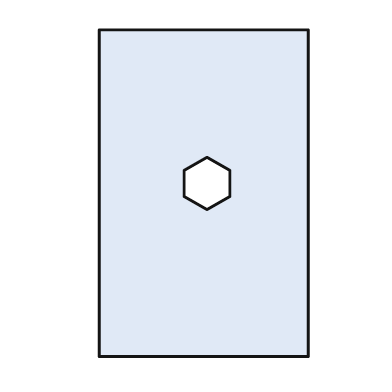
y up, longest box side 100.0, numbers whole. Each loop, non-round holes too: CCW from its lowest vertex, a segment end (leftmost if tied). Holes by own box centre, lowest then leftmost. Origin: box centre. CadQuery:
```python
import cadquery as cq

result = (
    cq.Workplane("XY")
    .moveTo(-32.0, -50.0)
    .lineTo(32.0, -50.0)
    .lineTo(32.0, 50.0)
    .lineTo(-32.0, 50.0)
    .close()
    .moveTo(1.0, -5.0)
    .lineTo(8.0, -1.0)
    .lineTo(8.0, 7.0)
    .lineTo(1.0, 11.0)
    .lineTo(-6.0, 7.0)
    .lineTo(-6.0, -1.0)
    .close()
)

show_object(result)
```